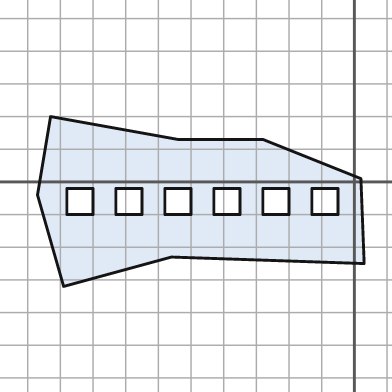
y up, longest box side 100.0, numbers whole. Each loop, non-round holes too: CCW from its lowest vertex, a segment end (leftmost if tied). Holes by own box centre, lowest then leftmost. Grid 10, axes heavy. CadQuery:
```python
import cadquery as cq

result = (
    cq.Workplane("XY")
    .moveTo(-89.0, -32.0)
    .lineTo(-56.0, -23.0)
    .lineTo(3.0, -25.0)
    .lineTo(2.0, 1.0)
    .lineTo(-28.0, 13.0)
    .lineTo(-54.0, 13.0)
    .lineTo(-93.0, 20.0)
    .lineTo(-97.0, -4.0)
    .close()
    .moveTo(-88.0, -10.0)
    .lineTo(-80.0, -10.0)
    .lineTo(-80.0, -2.0)
    .lineTo(-88.0, -2.0)
    .close()
    .moveTo(-73.0, -10.0)
    .lineTo(-65.0, -10.0)
    .lineTo(-65.0, -2.0)
    .lineTo(-73.0, -2.0)
    .close()
    .moveTo(-58.0, -10.0)
    .lineTo(-50.0, -10.0)
    .lineTo(-50.0, -2.0)
    .lineTo(-58.0, -2.0)
    .close()
    .moveTo(-43.0, -10.0)
    .lineTo(-35.0, -10.0)
    .lineTo(-35.0, -2.0)
    .lineTo(-43.0, -2.0)
    .close()
    .moveTo(-28.0, -10.0)
    .lineTo(-20.0, -10.0)
    .lineTo(-20.0, -2.0)
    .lineTo(-28.0, -2.0)
    .close()
    .moveTo(-13.0, -10.0)
    .lineTo(-5.0, -10.0)
    .lineTo(-5.0, -2.0)
    .lineTo(-13.0, -2.0)
    .close()
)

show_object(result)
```